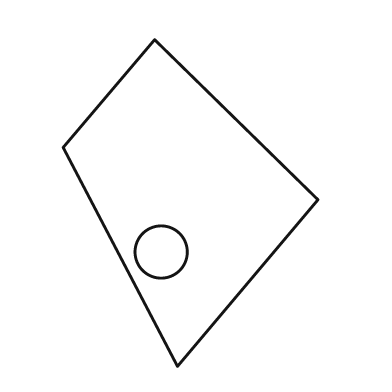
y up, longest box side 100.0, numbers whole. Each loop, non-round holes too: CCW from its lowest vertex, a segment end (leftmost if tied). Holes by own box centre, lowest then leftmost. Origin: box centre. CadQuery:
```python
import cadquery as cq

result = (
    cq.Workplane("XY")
    .moveTo(-4.0, -50.0)
    .lineTo(39.0, 1.0)
    .lineTo(-11.0, 50.0)
    .lineTo(-39.0, 17.0)
    .close()
    .moveTo(-9.0, -15.0)
    .circle(8.0)
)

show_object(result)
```